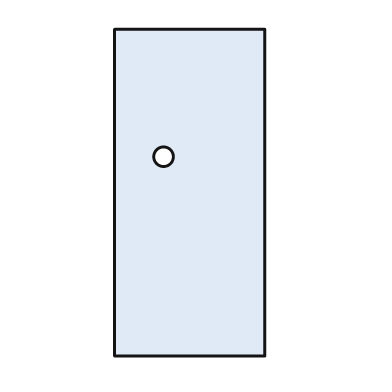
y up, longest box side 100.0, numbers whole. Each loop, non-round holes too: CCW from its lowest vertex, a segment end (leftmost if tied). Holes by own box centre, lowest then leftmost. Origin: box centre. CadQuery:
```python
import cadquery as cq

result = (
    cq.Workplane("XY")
    .moveTo(-23.0, -50.0)
    .lineTo(23.0, -50.0)
    .lineTo(23.0, 50.0)
    .lineTo(-23.0, 50.0)
    .close()
    .moveTo(-8.0, 11.0)
    .circle(3.0)
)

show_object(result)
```